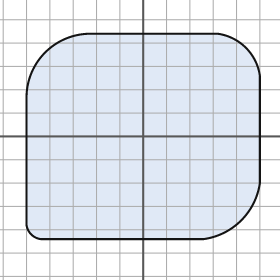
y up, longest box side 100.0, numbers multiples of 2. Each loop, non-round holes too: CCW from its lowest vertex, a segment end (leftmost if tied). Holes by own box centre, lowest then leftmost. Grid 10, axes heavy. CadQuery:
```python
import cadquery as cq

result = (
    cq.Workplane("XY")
    .moveTo(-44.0, -44.0)
    .lineTo(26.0, -44.0)
    .threePointArc((42.0, -36.0), (50.0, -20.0))
    .lineTo(50.0, 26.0)
    .threePointArc((44.0, 38.0), (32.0, 44.0))
    .lineTo(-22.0, 44.0)
    .threePointArc((-42.0, 36.0), (-50.0, 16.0))
    .lineTo(-50.0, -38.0)
    .threePointArc((-48.0, -42.0), (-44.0, -44.0))
    .close()
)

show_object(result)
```